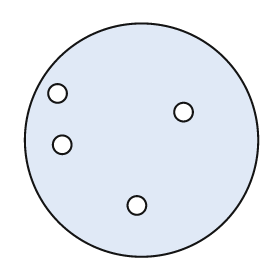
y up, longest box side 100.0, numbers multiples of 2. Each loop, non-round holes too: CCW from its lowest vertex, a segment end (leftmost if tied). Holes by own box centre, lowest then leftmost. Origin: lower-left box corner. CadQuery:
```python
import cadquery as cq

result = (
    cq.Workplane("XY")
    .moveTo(50.0, 50.0)
    .circle(50.0)
    .moveTo(48.0, 22.0)
    .circle(4.0)
    .moveTo(16.0, 48.0)
    .circle(4.0)
    .moveTo(68.0, 62.0)
    .circle(4.0)
    .moveTo(14.0, 70.0)
    .circle(4.0)
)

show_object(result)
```